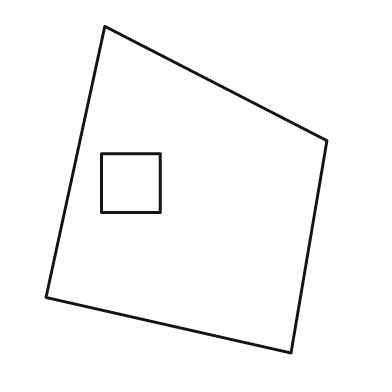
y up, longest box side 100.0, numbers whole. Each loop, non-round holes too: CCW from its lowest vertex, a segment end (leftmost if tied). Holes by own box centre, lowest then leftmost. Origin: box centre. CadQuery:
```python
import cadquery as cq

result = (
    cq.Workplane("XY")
    .moveTo(32.0, -50.0)
    .lineTo(43.0, 15.0)
    .lineTo(-25.0, 50.0)
    .lineTo(-43.0, -33.0)
    .close()
    .moveTo(-26.0, -7.0)
    .lineTo(-8.0, -7.0)
    .lineTo(-8.0, 11.0)
    .lineTo(-26.0, 11.0)
    .close()
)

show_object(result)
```